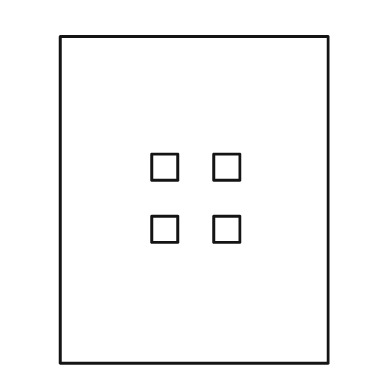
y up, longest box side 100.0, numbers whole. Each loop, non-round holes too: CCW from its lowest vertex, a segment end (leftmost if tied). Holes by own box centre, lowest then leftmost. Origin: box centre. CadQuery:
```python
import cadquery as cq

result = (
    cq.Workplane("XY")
    .moveTo(-41.0, -50.0)
    .lineTo(41.0, -50.0)
    .lineTo(41.0, 50.0)
    .lineTo(-41.0, 50.0)
    .close()
    .moveTo(-13.0, -13.0)
    .lineTo(-5.0, -13.0)
    .lineTo(-5.0, -5.0)
    .lineTo(-13.0, -5.0)
    .close()
    .moveTo(6.0, -13.0)
    .lineTo(14.0, -13.0)
    .lineTo(14.0, -5.0)
    .lineTo(6.0, -5.0)
    .close()
    .moveTo(-13.0, 6.0)
    .lineTo(-5.0, 6.0)
    .lineTo(-5.0, 14.0)
    .lineTo(-13.0, 14.0)
    .close()
    .moveTo(6.0, 6.0)
    .lineTo(14.0, 6.0)
    .lineTo(14.0, 14.0)
    .lineTo(6.0, 14.0)
    .close()
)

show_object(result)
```